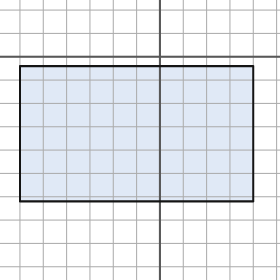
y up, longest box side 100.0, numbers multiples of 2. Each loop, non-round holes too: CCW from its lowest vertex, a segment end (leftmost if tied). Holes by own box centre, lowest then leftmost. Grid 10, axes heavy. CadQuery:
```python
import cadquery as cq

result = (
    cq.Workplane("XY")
    .moveTo(-60.0, -62.0)
    .lineTo(40.0, -62.0)
    .lineTo(40.0, -4.0)
    .lineTo(-60.0, -4.0)
    .close()
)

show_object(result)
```